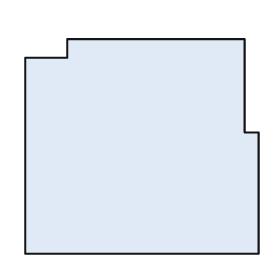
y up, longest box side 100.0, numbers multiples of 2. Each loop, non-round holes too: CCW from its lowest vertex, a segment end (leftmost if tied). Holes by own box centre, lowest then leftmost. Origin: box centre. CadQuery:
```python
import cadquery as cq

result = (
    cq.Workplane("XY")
    .moveTo(-50.0, -46.0)
    .lineTo(50.0, -46.0)
    .lineTo(50.0, 6.0)
    .lineTo(44.0, 6.0)
    .lineTo(44.0, 46.0)
    .lineTo(-32.0, 46.0)
    .lineTo(-32.0, 38.0)
    .lineTo(-50.0, 38.0)
    .close()
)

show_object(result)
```